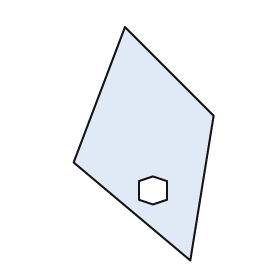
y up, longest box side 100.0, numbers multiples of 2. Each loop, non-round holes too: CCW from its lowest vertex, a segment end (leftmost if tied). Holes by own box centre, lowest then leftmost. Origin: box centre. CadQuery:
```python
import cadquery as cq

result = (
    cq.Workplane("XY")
    .moveTo(20.0, -50.0)
    .lineTo(30.0, 12.0)
    .lineTo(-8.0, 50.0)
    .lineTo(-30.0, -8.0)
    .close()
    .moveTo(4.0, -26.0)
    .lineTo(10.0, -24.0)
    .lineTo(10.0, -16.0)
    .lineTo(4.0, -14.0)
    .lineTo(-2.0, -16.0)
    .lineTo(-2.0, -24.0)
    .close()
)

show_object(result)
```